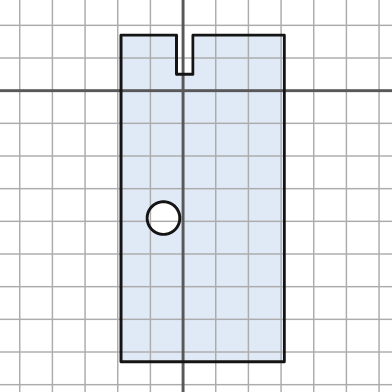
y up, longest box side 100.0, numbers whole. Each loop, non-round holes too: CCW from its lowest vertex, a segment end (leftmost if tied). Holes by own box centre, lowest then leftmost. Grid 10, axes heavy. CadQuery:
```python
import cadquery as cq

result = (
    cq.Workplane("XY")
    .moveTo(-19.0, -83.0)
    .lineTo(31.0, -83.0)
    .lineTo(31.0, 17.0)
    .lineTo(3.0, 17.0)
    .lineTo(3.0, 5.0)
    .lineTo(-2.0, 5.0)
    .lineTo(-2.0, 17.0)
    .lineTo(-19.0, 17.0)
    .close()
    .moveTo(-6.0, -39.0)
    .circle(5.0)
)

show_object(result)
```